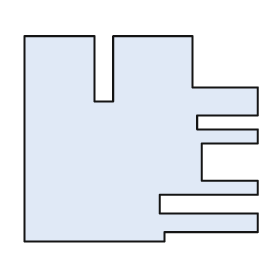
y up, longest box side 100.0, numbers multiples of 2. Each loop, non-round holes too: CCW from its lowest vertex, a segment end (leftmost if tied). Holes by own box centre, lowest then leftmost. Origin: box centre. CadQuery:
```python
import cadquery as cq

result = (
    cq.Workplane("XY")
    .moveTo(-50.0, -44.0)
    .lineTo(10.0, -44.0)
    .lineTo(10.0, -40.0)
    .lineTo(50.0, -40.0)
    .lineTo(50.0, -32.0)
    .lineTo(8.0, -32.0)
    .lineTo(8.0, -24.0)
    .lineTo(50.0, -24.0)
    .lineTo(50.0, -18.0)
    .lineTo(26.0, -18.0)
    .lineTo(26.0, -2.0)
    .lineTo(50.0, -2.0)
    .lineTo(50.0, 4.0)
    .lineTo(24.0, 4.0)
    .lineTo(24.0, 10.0)
    .lineTo(50.0, 10.0)
    .lineTo(50.0, 22.0)
    .lineTo(22.0, 22.0)
    .lineTo(22.0, 44.0)
    .lineTo(-12.0, 44.0)
    .lineTo(-12.0, 16.0)
    .lineTo(-20.0, 16.0)
    .lineTo(-20.0, 44.0)
    .lineTo(-50.0, 44.0)
    .close()
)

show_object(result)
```